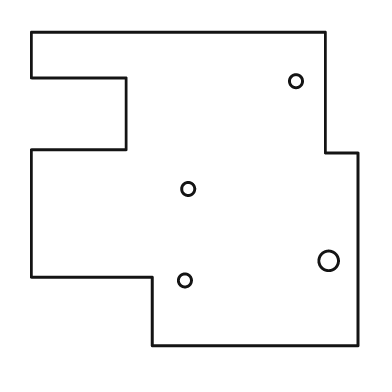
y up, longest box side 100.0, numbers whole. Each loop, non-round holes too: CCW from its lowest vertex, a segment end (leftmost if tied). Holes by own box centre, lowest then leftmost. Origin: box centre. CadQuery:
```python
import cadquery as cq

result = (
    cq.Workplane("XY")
    .moveTo(-13.0, -48.0)
    .lineTo(50.0, -48.0)
    .lineTo(50.0, 11.0)
    .lineTo(40.0, 11.0)
    .lineTo(40.0, 48.0)
    .lineTo(-50.0, 48.0)
    .lineTo(-50.0, 34.0)
    .lineTo(-21.0, 34.0)
    .lineTo(-21.0, 12.0)
    .lineTo(-50.0, 12.0)
    .lineTo(-50.0, -27.0)
    .lineTo(-13.0, -27.0)
    .close()
    .moveTo(-3.0, -28.0)
    .circle(2.0)
    .moveTo(41.0, -22.0)
    .circle(3.0)
    .moveTo(-2.0, 0.0)
    .circle(2.0)
    .moveTo(31.0, 33.0)
    .circle(2.0)
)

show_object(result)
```